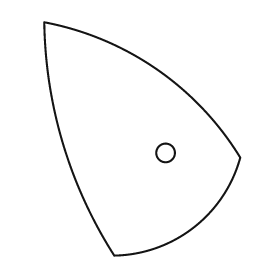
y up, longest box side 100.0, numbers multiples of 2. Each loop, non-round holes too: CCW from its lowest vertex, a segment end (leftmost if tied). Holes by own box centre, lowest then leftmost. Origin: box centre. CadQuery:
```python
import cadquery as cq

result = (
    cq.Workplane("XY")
    .moveTo(-12.0, -50.0)
    .threePointArc((22.0, -38.0), (42.0, -8.0))
    .threePointArc((6.0, 30.0), (-42.0, 50.0))
    .threePointArc((-34.0, -2.0), (-12.0, -50.0))
    .close()
    .moveTo(10.0, -6.0)
    .circle(4.0)
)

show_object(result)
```